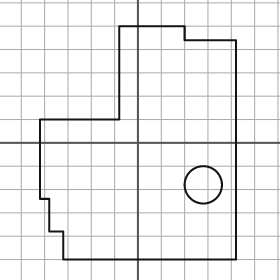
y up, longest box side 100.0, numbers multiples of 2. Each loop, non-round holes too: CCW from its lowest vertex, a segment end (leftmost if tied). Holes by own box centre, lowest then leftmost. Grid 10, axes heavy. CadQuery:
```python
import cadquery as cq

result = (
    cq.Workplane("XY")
    .moveTo(-32.0, -50.0)
    .lineTo(42.0, -50.0)
    .lineTo(42.0, 44.0)
    .lineTo(20.0, 44.0)
    .lineTo(20.0, 50.0)
    .lineTo(-8.0, 50.0)
    .lineTo(-8.0, 10.0)
    .lineTo(-42.0, 10.0)
    .lineTo(-42.0, -24.0)
    .lineTo(-38.0, -24.0)
    .lineTo(-38.0, -38.0)
    .lineTo(-32.0, -38.0)
    .close()
    .moveTo(28.0, -18.0)
    .circle(8.0)
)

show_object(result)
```